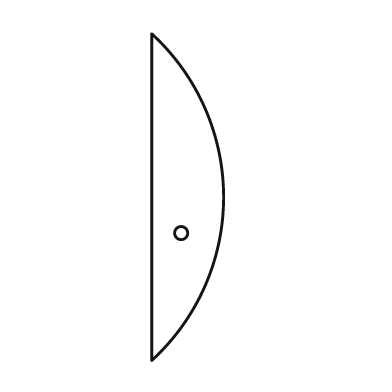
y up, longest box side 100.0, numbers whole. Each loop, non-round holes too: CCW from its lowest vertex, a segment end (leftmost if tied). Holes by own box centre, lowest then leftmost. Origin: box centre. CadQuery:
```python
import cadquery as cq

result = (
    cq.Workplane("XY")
    .moveTo(-11.0, -50.0)
    .threePointArc((11.0, 0.0), (-11.0, 50.0))
    .close()
    .moveTo(-2.0, -11.0)
    .circle(2.0)
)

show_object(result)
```